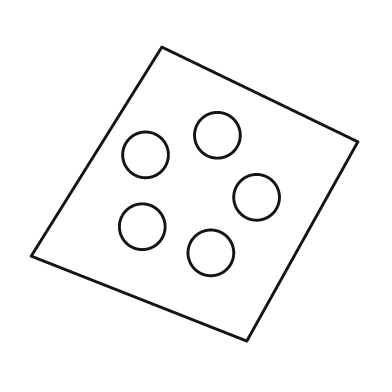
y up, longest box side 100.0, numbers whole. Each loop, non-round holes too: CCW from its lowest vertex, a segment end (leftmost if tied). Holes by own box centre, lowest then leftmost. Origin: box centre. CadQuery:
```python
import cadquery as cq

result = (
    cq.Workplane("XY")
    .moveTo(16.0, -45.0)
    .lineTo(50.0, 16.0)
    .lineTo(-10.0, 45.0)
    .lineTo(-50.0, -19.0)
    .close()
    .moveTo(5.0, -18.0)
    .circle(7.0)
    .moveTo(-16.0, -10.0)
    .circle(7.0)
    .moveTo(19.0, -1.0)
    .circle(7.0)
    .moveTo(-15.0, 12.0)
    .circle(7.0)
    .moveTo(7.0, 18.0)
    .circle(7.0)
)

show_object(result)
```